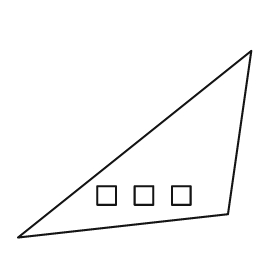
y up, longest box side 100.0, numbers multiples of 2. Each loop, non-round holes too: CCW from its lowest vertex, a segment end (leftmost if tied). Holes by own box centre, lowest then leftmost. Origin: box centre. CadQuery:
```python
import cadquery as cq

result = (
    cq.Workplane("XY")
    .moveTo(-50.0, -40.0)
    .lineTo(40.0, -30.0)
    .lineTo(50.0, 40.0)
    .close()
    .moveTo(-16.0, -26.0)
    .lineTo(-8.0, -26.0)
    .lineTo(-8.0, -18.0)
    .lineTo(-16.0, -18.0)
    .close()
    .moveTo(0.0, -26.0)
    .lineTo(8.0, -26.0)
    .lineTo(8.0, -18.0)
    .lineTo(0.0, -18.0)
    .close()
    .moveTo(16.0, -26.0)
    .lineTo(24.0, -26.0)
    .lineTo(24.0, -18.0)
    .lineTo(16.0, -18.0)
    .close()
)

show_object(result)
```